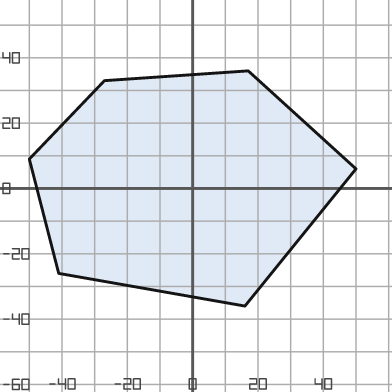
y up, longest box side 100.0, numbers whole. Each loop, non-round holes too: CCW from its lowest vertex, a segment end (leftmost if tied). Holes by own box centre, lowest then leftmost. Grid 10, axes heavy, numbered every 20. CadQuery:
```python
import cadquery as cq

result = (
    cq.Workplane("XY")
    .moveTo(16.0, -36.0)
    .lineTo(50.0, 6.0)
    .lineTo(17.0, 36.0)
    .lineTo(-27.0, 33.0)
    .lineTo(-50.0, 9.0)
    .lineTo(-41.0, -26.0)
    .close()
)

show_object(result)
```